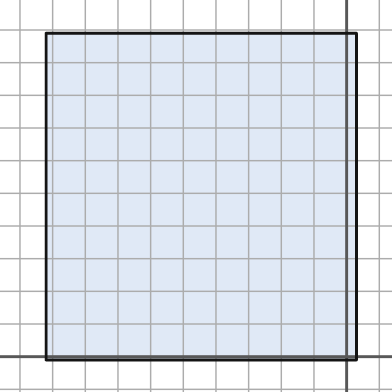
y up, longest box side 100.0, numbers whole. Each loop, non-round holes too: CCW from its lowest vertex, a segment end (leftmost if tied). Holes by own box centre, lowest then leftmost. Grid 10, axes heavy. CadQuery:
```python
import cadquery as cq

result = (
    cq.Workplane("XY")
    .moveTo(-92.0, -1.0)
    .lineTo(3.0, -1.0)
    .lineTo(3.0, 99.0)
    .lineTo(-92.0, 99.0)
    .close()
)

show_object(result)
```